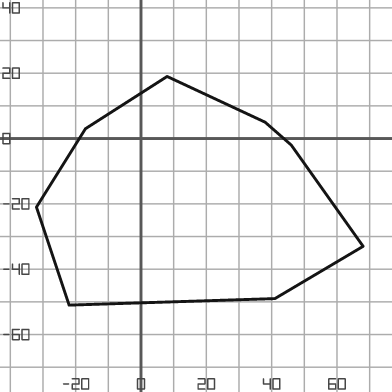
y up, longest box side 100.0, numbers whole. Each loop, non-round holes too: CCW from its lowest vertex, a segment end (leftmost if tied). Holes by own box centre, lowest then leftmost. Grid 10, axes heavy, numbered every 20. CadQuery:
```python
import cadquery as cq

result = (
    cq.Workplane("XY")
    .moveTo(-22.0, -51.0)
    .lineTo(41.0, -49.0)
    .lineTo(68.0, -33.0)
    .lineTo(46.0, -2.0)
    .lineTo(38.0, 5.0)
    .lineTo(8.0, 19.0)
    .lineTo(-17.0, 3.0)
    .lineTo(-32.0, -21.0)
    .close()
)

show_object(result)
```